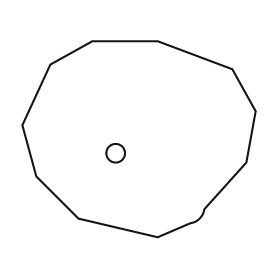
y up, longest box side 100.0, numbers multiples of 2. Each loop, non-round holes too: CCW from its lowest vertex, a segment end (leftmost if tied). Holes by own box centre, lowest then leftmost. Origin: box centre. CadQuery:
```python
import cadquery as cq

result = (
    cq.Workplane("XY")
    .moveTo(8.0, -42.0)
    .lineTo(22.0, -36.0)
    .threePointArc((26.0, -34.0), (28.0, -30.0))
    .lineTo(46.0, -10.0)
    .lineTo(50.0, 12.0)
    .lineTo(40.0, 30.0)
    .lineTo(8.0, 42.0)
    .lineTo(-20.0, 42.0)
    .lineTo(-38.0, 32.0)
    .lineTo(-50.0, 6.0)
    .lineTo(-44.0, -16.0)
    .lineTo(-26.0, -34.0)
    .close()
    .moveTo(-10.0, -6.0)
    .circle(4.0)
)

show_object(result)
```